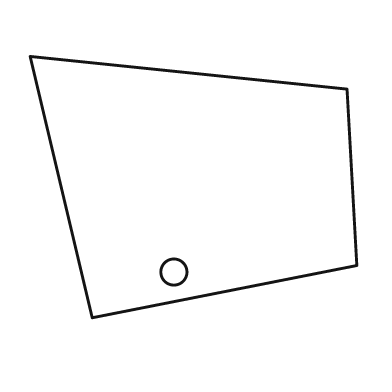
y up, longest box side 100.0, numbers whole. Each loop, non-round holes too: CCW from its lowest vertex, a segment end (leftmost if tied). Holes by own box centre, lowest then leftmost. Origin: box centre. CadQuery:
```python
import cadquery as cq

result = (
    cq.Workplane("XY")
    .moveTo(-31.0, -40.0)
    .lineTo(50.0, -24.0)
    .lineTo(47.0, 30.0)
    .lineTo(-50.0, 40.0)
    .close()
    .moveTo(-6.0, -26.0)
    .circle(4.0)
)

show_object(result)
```